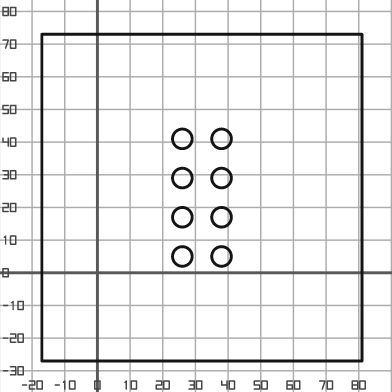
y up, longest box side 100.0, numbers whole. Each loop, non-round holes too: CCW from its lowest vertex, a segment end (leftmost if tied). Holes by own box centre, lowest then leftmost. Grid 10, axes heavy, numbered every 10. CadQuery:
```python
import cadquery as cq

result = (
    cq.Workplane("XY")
    .moveTo(-17.0, -27.0)
    .lineTo(81.0, -27.0)
    .lineTo(81.0, 73.0)
    .lineTo(-17.0, 73.0)
    .close()
    .moveTo(26.0, 5.0)
    .circle(3.0)
    .moveTo(38.0, 5.0)
    .circle(3.0)
    .moveTo(26.0, 17.0)
    .circle(3.0)
    .moveTo(38.0, 17.0)
    .circle(3.0)
    .moveTo(26.0, 29.0)
    .circle(3.0)
    .moveTo(38.0, 29.0)
    .circle(3.0)
    .moveTo(26.0, 41.0)
    .circle(3.0)
    .moveTo(38.0, 41.0)
    .circle(3.0)
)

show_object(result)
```